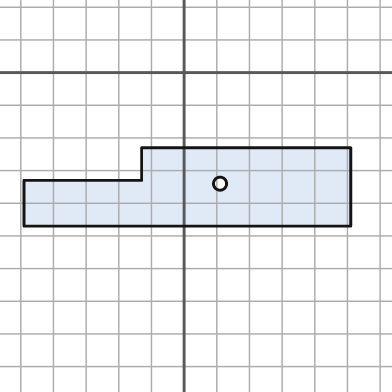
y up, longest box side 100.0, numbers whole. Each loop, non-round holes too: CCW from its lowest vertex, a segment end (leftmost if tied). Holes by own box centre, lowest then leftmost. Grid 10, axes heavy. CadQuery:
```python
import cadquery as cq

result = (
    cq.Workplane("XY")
    .moveTo(-49.0, -47.0)
    .lineTo(51.0, -47.0)
    .lineTo(51.0, -23.0)
    .lineTo(-13.0, -23.0)
    .lineTo(-13.0, -33.0)
    .lineTo(-49.0, -33.0)
    .close()
    .moveTo(11.0, -34.0)
    .circle(2.0)
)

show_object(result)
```